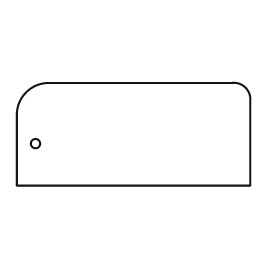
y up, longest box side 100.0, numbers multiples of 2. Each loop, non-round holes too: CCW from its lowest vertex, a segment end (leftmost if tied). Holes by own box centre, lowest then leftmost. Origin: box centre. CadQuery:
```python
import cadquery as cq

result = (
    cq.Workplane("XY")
    .moveTo(-50.0, -22.0)
    .lineTo(50.0, -22.0)
    .lineTo(50.0, 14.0)
    .threePointArc((48.0, 20.0), (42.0, 22.0))
    .lineTo(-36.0, 22.0)
    .threePointArc((-46.0, 18.0), (-50.0, 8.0))
    .close()
    .moveTo(-42.0, -4.0)
    .circle(2.0)
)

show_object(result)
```